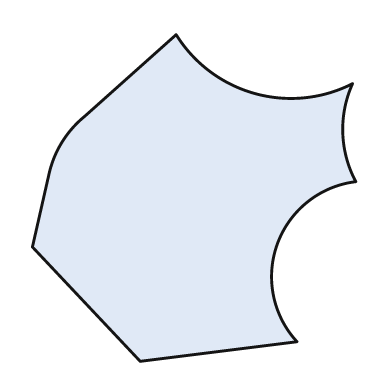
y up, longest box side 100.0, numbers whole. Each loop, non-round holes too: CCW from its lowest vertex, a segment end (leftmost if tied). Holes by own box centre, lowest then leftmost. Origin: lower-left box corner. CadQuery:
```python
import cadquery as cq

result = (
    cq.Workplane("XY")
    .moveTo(33.0, 0.0)
    .lineTo(81.0, 6.0)
    .threePointArc((75.0, 36.0), (99.0, 55.0))
    .threePointArc((95.0, 70.0), (98.0, 85.0))
    .threePointArc((68.0, 82.0), (44.0, 100.0))
    .lineTo(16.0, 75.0)
    .threePointArc((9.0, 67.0), (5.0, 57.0))
    .lineTo(0.0, 35.0)
    .close()
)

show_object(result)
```